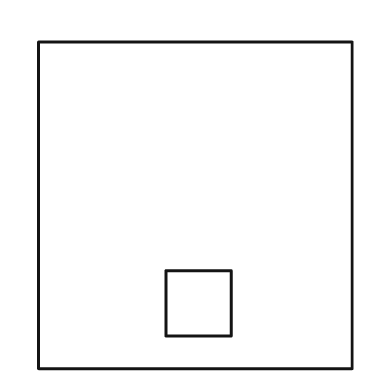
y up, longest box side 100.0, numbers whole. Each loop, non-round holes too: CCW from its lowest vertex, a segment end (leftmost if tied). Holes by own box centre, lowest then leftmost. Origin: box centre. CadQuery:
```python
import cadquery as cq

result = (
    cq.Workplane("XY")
    .moveTo(-48.0, -50.0)
    .lineTo(48.0, -50.0)
    .lineTo(48.0, 50.0)
    .lineTo(-48.0, 50.0)
    .close()
    .moveTo(-9.0, -40.0)
    .lineTo(11.0, -40.0)
    .lineTo(11.0, -20.0)
    .lineTo(-9.0, -20.0)
    .close()
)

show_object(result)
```